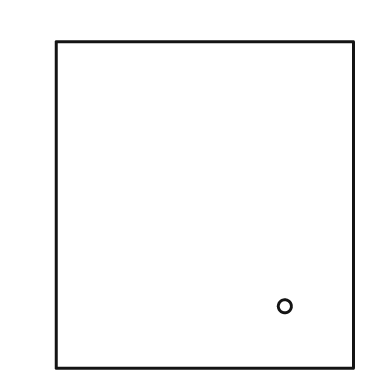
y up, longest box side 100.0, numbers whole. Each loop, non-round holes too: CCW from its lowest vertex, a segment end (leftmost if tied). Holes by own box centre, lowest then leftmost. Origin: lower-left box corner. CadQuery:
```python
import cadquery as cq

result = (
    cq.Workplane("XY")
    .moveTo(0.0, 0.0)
    .lineTo(91.0, 0.0)
    .lineTo(91.0, 100.0)
    .lineTo(0.0, 100.0)
    .close()
    .moveTo(70.0, 19.0)
    .circle(2.0)
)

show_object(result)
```